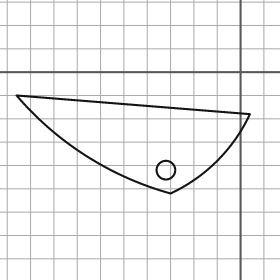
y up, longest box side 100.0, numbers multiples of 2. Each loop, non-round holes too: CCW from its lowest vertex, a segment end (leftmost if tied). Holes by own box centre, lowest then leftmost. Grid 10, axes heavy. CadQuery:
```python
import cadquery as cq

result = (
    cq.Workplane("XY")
    .moveTo(-30.0, -52.0)
    .threePointArc((-10.0, -38.0), (4.0, -18.0))
    .lineTo(-96.0, -10.0)
    .threePointArc((-66.0, -36.0), (-30.0, -52.0))
    .close()
    .moveTo(-32.0, -42.0)
    .circle(4.0)
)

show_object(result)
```